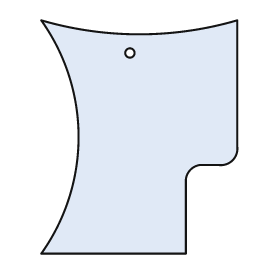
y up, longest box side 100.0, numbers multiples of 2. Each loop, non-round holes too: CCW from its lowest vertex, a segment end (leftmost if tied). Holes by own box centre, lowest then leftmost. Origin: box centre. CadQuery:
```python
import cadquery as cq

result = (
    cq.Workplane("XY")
    .moveTo(-42.0, -50.0)
    .lineTo(20.0, -50.0)
    .lineTo(20.0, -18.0)
    .threePointArc((22.0, -14.0), (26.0, -12.0))
    .lineTo(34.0, -12.0)
    .threePointArc((40.0, -10.0), (42.0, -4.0))
    .lineTo(42.0, 50.0)
    .threePointArc((0.0, 44.0), (-42.0, 50.0))
    .threePointArc((-26.0, 0.0), (-42.0, -50.0))
    .close()
    .moveTo(-4.0, 36.0)
    .circle(2.0)
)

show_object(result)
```